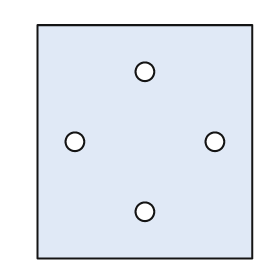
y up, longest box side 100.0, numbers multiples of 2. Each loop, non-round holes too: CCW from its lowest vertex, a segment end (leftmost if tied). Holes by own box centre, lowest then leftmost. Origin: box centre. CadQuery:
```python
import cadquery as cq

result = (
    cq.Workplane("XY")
    .moveTo(-46.0, -50.0)
    .lineTo(46.0, -50.0)
    .lineTo(46.0, 50.0)
    .lineTo(-46.0, 50.0)
    .close()
    .moveTo(0.0, -30.0)
    .circle(4.0)
    .moveTo(-30.0, 0.0)
    .circle(4.0)
    .moveTo(30.0, 0.0)
    .circle(4.0)
    .moveTo(0.0, 30.0)
    .circle(4.0)
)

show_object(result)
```